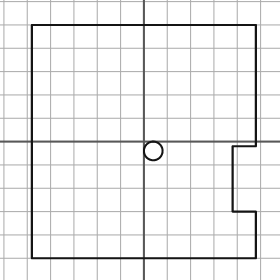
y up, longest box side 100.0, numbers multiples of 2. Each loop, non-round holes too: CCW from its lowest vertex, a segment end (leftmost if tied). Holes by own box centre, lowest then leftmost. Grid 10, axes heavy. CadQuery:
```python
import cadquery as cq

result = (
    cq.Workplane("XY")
    .moveTo(-48.0, -50.0)
    .lineTo(48.0, -50.0)
    .lineTo(48.0, -30.0)
    .lineTo(38.0, -30.0)
    .lineTo(38.0, -2.0)
    .lineTo(48.0, -2.0)
    .lineTo(48.0, 50.0)
    .lineTo(-48.0, 50.0)
    .close()
    .moveTo(4.0, -4.0)
    .circle(4.0)
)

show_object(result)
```